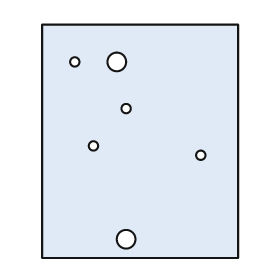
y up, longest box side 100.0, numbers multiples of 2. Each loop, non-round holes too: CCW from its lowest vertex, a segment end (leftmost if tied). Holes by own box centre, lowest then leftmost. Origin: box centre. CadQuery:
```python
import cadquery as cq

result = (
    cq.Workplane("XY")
    .moveTo(-42.0, -50.0)
    .lineTo(42.0, -50.0)
    .lineTo(42.0, 50.0)
    .lineTo(-42.0, 50.0)
    .close()
    .moveTo(-6.0, -42.0)
    .circle(4.0)
    .moveTo(26.0, -6.0)
    .circle(2.0)
    .moveTo(-20.0, -2.0)
    .circle(2.0)
    .moveTo(-6.0, 14.0)
    .circle(2.0)
    .moveTo(-28.0, 34.0)
    .circle(2.0)
    .moveTo(-10.0, 34.0)
    .circle(4.0)
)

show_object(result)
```